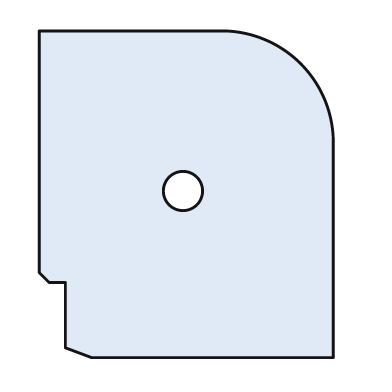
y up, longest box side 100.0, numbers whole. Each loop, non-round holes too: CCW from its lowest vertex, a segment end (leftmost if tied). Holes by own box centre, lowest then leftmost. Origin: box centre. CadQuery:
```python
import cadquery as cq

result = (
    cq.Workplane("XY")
    .moveTo(-29.0, -50.0)
    .lineTo(45.0, -50.0)
    .lineTo(45.0, 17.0)
    .threePointArc((35.0, 40.0), (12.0, 50.0))
    .lineTo(-45.0, 50.0)
    .lineTo(-45.0, -24.0)
    .lineTo(-42.0, -27.0)
    .lineTo(-37.0, -27.0)
    .lineTo(-37.0, -47.0)
    .close()
    .moveTo(-1.0, 1.0)
    .circle(6.0)
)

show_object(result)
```